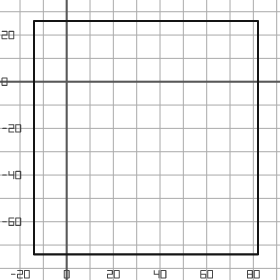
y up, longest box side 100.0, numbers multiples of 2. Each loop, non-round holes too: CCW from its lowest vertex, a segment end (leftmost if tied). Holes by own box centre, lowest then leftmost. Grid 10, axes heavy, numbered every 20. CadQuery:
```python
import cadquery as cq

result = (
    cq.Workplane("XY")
    .moveTo(-14.0, -74.0)
    .lineTo(82.0, -74.0)
    .lineTo(82.0, 26.0)
    .lineTo(-14.0, 26.0)
    .close()
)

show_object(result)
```